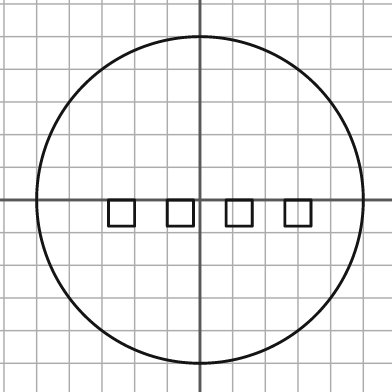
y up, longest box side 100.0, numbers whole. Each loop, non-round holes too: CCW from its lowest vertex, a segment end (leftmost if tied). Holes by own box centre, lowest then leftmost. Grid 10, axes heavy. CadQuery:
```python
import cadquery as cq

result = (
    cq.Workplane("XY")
    .moveTo(0.0, 0.0)
    .circle(50.0)
    .moveTo(-28.0, -8.0)
    .lineTo(-20.0, -8.0)
    .lineTo(-20.0, 0.0)
    .lineTo(-28.0, 0.0)
    .close()
    .moveTo(-10.0, -8.0)
    .lineTo(-2.0, -8.0)
    .lineTo(-2.0, 0.0)
    .lineTo(-10.0, 0.0)
    .close()
    .moveTo(8.0, -8.0)
    .lineTo(16.0, -8.0)
    .lineTo(16.0, 0.0)
    .lineTo(8.0, 0.0)
    .close()
    .moveTo(26.0, -8.0)
    .lineTo(34.0, -8.0)
    .lineTo(34.0, 0.0)
    .lineTo(26.0, 0.0)
    .close()
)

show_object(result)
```